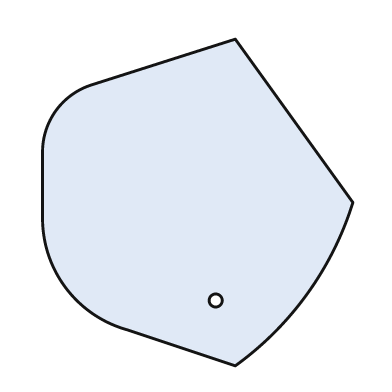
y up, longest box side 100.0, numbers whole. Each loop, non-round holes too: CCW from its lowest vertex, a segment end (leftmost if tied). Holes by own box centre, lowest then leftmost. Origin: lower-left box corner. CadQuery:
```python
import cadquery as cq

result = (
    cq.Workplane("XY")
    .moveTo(59.0, 0.0)
    .threePointArc((81.0, 22.0), (95.0, 50.0))
    .lineTo(59.0, 100.0)
    .lineTo(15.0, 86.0)
    .threePointArc((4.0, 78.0), (0.0, 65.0))
    .lineTo(0.0, 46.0)
    .threePointArc((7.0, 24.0), (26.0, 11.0))
    .close()
    .moveTo(53.0, 20.0)
    .circle(2.0)
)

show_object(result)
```